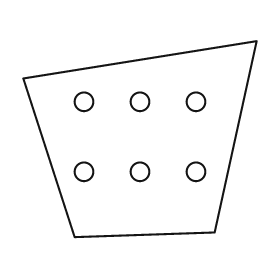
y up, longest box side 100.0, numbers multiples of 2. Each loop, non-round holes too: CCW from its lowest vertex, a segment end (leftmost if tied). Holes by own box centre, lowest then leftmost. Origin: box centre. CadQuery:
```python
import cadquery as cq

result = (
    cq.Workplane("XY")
    .moveTo(-28.0, -42.0)
    .lineTo(32.0, -40.0)
    .lineTo(50.0, 42.0)
    .lineTo(-50.0, 26.0)
    .close()
    .moveTo(-24.0, -14.0)
    .circle(4.0)
    .moveTo(0.0, -14.0)
    .circle(4.0)
    .moveTo(24.0, -14.0)
    .circle(4.0)
    .moveTo(-24.0, 16.0)
    .circle(4.0)
    .moveTo(0.0, 16.0)
    .circle(4.0)
    .moveTo(24.0, 16.0)
    .circle(4.0)
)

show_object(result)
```